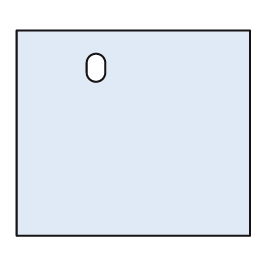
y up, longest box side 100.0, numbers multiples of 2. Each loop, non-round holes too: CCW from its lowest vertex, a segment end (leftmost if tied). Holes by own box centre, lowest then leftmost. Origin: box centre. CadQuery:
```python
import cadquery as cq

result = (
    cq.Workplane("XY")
    .moveTo(-50.0, -44.0)
    .lineTo(50.0, -44.0)
    .lineTo(50.0, 44.0)
    .lineTo(-50.0, 44.0)
    .close()
    .moveTo(-20.0, 26.0)
    .threePointArc((-16.0, 22.0), (-12.0, 26.0))
    .lineTo(-12.0, 30.0)
    .threePointArc((-16.0, 34.0), (-20.0, 30.0))
    .close()
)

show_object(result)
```